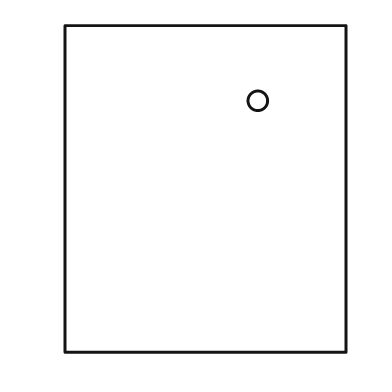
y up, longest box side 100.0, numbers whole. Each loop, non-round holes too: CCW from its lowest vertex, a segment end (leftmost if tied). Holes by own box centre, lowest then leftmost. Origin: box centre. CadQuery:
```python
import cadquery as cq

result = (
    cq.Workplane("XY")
    .moveTo(-43.0, -50.0)
    .lineTo(43.0, -50.0)
    .lineTo(43.0, 50.0)
    .lineTo(-43.0, 50.0)
    .close()
    .moveTo(16.0, 27.0)
    .circle(3.0)
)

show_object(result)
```